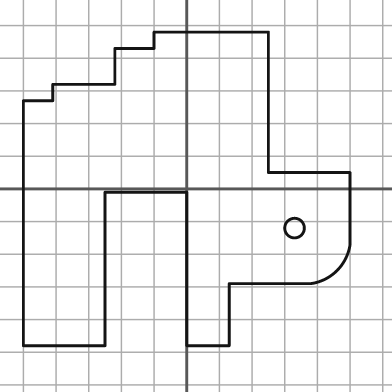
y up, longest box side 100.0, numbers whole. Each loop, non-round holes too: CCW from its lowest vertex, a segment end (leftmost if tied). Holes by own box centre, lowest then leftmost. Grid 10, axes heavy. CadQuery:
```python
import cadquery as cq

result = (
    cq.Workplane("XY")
    .moveTo(-50.0, -48.0)
    .lineTo(-25.0, -48.0)
    .lineTo(-25.0, -1.0)
    .lineTo(0.0, -1.0)
    .lineTo(0.0, -48.0)
    .lineTo(13.0, -48.0)
    .lineTo(13.0, -29.0)
    .lineTo(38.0, -29.0)
    .threePointArc((46.0, -25.0), (50.0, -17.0))
    .lineTo(50.0, 5.0)
    .lineTo(25.0, 5.0)
    .lineTo(25.0, 48.0)
    .lineTo(-10.0, 48.0)
    .lineTo(-10.0, 43.0)
    .lineTo(-22.0, 43.0)
    .lineTo(-22.0, 32.0)
    .lineTo(-41.0, 32.0)
    .lineTo(-41.0, 27.0)
    .lineTo(-50.0, 27.0)
    .close()
    .moveTo(33.0, -12.0)
    .circle(3.0)
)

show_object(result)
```